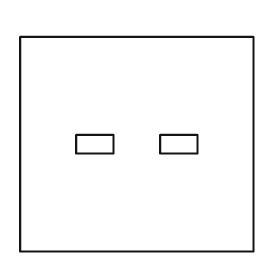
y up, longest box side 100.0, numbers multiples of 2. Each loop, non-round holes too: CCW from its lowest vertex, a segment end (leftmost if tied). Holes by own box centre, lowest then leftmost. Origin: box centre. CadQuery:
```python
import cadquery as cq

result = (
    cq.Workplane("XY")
    .moveTo(-50.0, -46.0)
    .lineTo(50.0, -46.0)
    .lineTo(50.0, 46.0)
    .lineTo(-50.0, 46.0)
    .close()
    .moveTo(-26.0, -4.0)
    .lineTo(-10.0, -4.0)
    .lineTo(-10.0, 4.0)
    .lineTo(-26.0, 4.0)
    .close()
    .moveTo(10.0, -4.0)
    .lineTo(26.0, -4.0)
    .lineTo(26.0, 4.0)
    .lineTo(10.0, 4.0)
    .close()
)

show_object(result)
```